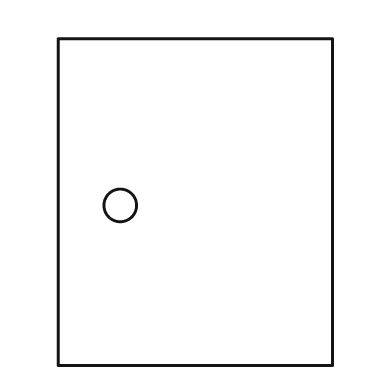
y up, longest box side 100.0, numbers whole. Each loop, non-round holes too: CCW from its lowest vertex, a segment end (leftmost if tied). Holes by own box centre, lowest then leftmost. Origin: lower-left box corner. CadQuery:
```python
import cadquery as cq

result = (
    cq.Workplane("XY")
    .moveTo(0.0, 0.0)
    .lineTo(84.0, 0.0)
    .lineTo(84.0, 100.0)
    .lineTo(0.0, 100.0)
    .close()
    .moveTo(19.0, 49.0)
    .circle(5.0)
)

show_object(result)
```